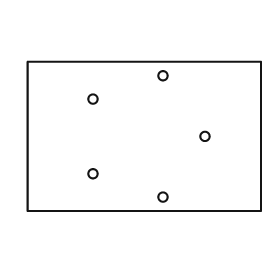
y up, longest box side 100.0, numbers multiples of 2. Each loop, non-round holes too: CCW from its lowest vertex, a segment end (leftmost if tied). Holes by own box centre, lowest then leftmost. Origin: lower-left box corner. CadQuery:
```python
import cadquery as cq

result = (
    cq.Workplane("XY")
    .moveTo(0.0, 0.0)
    .lineTo(100.0, 0.0)
    .lineTo(100.0, 64.0)
    .lineTo(0.0, 64.0)
    .close()
    .moveTo(58.0, 6.0)
    .circle(2.0)
    .moveTo(28.0, 16.0)
    .circle(2.0)
    .moveTo(76.0, 32.0)
    .circle(2.0)
    .moveTo(28.0, 48.0)
    .circle(2.0)
    .moveTo(58.0, 58.0)
    .circle(2.0)
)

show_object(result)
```